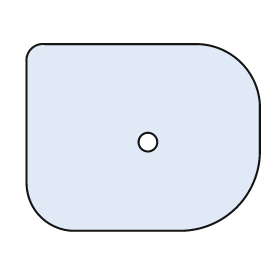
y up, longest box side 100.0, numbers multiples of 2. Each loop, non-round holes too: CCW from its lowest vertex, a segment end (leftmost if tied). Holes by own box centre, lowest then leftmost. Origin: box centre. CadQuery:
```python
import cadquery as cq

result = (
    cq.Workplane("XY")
    .moveTo(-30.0, -40.0)
    .lineTo(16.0, -40.0)
    .threePointArc((40.0, -30.0), (50.0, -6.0))
    .lineTo(50.0, 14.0)
    .threePointArc((42.0, 32.0), (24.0, 40.0))
    .lineTo(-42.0, 40.0)
    .threePointArc((-48.0, 38.0), (-50.0, 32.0))
    .lineTo(-50.0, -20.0)
    .threePointArc((-44.0, -34.0), (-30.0, -40.0))
    .close()
    .moveTo(2.0, -2.0)
    .circle(4.0)
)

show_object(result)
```